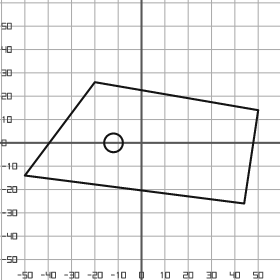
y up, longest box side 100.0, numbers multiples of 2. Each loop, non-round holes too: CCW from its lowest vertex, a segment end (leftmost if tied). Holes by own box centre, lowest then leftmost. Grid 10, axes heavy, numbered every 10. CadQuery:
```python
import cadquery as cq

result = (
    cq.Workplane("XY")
    .moveTo(44.0, -26.0)
    .lineTo(50.0, 14.0)
    .lineTo(-20.0, 26.0)
    .lineTo(-50.0, -14.0)
    .close()
    .moveTo(-12.0, 0.0)
    .circle(4.0)
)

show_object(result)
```